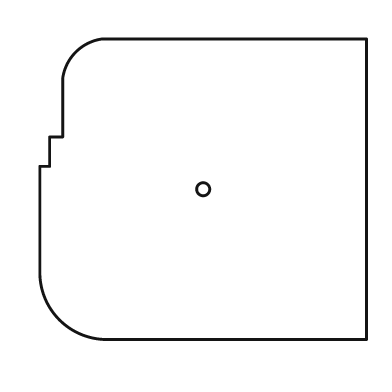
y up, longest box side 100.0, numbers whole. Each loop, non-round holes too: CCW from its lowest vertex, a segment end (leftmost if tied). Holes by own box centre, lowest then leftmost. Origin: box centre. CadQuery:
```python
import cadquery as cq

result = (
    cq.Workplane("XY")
    .moveTo(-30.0, -46.0)
    .lineTo(50.0, -46.0)
    .lineTo(50.0, 46.0)
    .lineTo(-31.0, 46.0)
    .threePointArc((-39.0, 42.0), (-43.0, 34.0))
    .lineTo(-43.0, 16.0)
    .lineTo(-47.0, 16.0)
    .lineTo(-47.0, 7.0)
    .lineTo(-50.0, 7.0)
    .lineTo(-50.0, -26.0)
    .threePointArc((-44.0, -40.0), (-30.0, -46.0))
    .close()
    .moveTo(0.0, 0.0)
    .circle(2.0)
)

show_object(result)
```